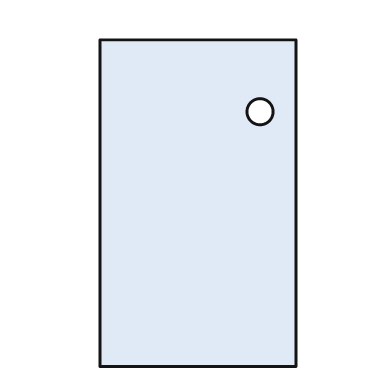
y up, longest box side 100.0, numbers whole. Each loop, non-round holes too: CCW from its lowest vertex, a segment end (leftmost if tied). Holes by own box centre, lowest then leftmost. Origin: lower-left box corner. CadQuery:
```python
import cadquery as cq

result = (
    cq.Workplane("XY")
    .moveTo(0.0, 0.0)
    .lineTo(60.0, 0.0)
    .lineTo(60.0, 100.0)
    .lineTo(0.0, 100.0)
    .close()
    .moveTo(49.0, 78.0)
    .circle(4.0)
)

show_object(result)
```